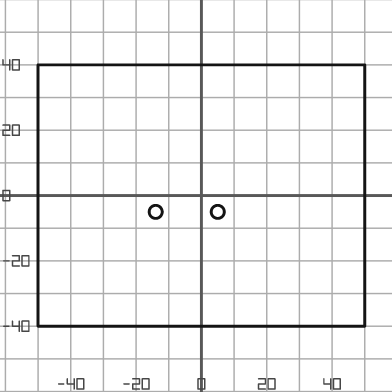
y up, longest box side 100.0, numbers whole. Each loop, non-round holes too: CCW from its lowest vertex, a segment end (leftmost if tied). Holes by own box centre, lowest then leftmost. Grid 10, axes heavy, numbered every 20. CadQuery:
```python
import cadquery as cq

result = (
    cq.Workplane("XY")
    .moveTo(-50.0, -40.0)
    .lineTo(50.0, -40.0)
    .lineTo(50.0, 40.0)
    .lineTo(-50.0, 40.0)
    .close()
    .moveTo(-14.0, -5.0)
    .circle(2.0)
    .moveTo(5.0, -5.0)
    .circle(2.0)
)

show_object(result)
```